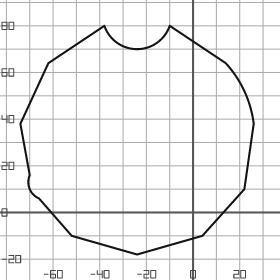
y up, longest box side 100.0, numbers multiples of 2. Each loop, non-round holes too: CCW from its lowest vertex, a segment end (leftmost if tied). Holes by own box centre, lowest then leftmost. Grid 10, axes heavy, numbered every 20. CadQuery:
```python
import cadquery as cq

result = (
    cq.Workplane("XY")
    .moveTo(-24.0, -18.0)
    .lineTo(4.0, -10.0)
    .lineTo(22.0, 10.0)
    .lineTo(26.0, 38.0)
    .threePointArc((22.0, 52.0), (14.0, 64.0))
    .lineTo(-10.0, 80.0)
    .threePointArc((-24.0, 70.0), (-38.0, 80.0))
    .lineTo(-62.0, 64.0)
    .lineTo(-74.0, 38.0)
    .lineTo(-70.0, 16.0)
    .threePointArc((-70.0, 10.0), (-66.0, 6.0))
    .lineTo(-52.0, -10.0)
    .close()
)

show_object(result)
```